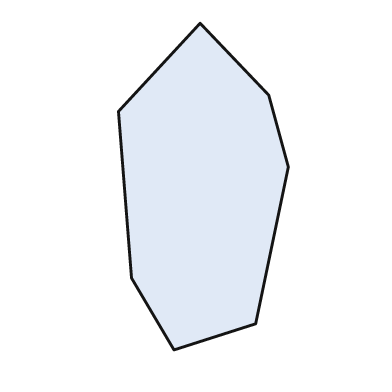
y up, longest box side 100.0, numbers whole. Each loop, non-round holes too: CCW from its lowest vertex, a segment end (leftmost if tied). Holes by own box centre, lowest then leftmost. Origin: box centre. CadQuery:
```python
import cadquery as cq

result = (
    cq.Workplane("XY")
    .moveTo(-9.0, -50.0)
    .lineTo(16.0, -42.0)
    .lineTo(26.0, 6.0)
    .lineTo(20.0, 28.0)
    .lineTo(-1.0, 50.0)
    .lineTo(-26.0, 23.0)
    .lineTo(-22.0, -28.0)
    .close()
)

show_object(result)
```